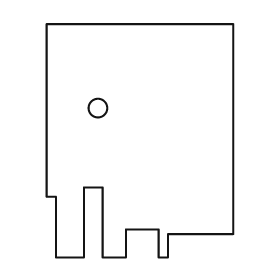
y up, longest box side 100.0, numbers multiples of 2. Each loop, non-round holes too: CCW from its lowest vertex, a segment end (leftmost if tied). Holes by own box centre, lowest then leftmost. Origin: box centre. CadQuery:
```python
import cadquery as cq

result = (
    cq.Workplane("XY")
    .moveTo(-36.0, -50.0)
    .lineTo(-24.0, -50.0)
    .lineTo(-24.0, -20.0)
    .lineTo(-16.0, -20.0)
    .lineTo(-16.0, -50.0)
    .lineTo(-6.0, -50.0)
    .lineTo(-6.0, -38.0)
    .lineTo(8.0, -38.0)
    .lineTo(8.0, -50.0)
    .lineTo(12.0, -50.0)
    .lineTo(12.0, -40.0)
    .lineTo(40.0, -40.0)
    .lineTo(40.0, 50.0)
    .lineTo(-40.0, 50.0)
    .lineTo(-40.0, -24.0)
    .lineTo(-36.0, -24.0)
    .close()
    .moveTo(-18.0, 14.0)
    .circle(4.0)
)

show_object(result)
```